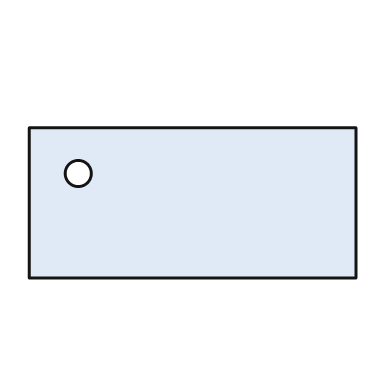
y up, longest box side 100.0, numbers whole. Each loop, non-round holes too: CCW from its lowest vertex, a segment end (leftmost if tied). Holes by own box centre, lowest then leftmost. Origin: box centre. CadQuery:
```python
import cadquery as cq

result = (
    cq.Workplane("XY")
    .moveTo(-50.0, -23.0)
    .lineTo(50.0, -23.0)
    .lineTo(50.0, 23.0)
    .lineTo(-50.0, 23.0)
    .close()
    .moveTo(-35.0, 9.0)
    .circle(4.0)
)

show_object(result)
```